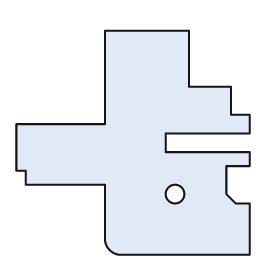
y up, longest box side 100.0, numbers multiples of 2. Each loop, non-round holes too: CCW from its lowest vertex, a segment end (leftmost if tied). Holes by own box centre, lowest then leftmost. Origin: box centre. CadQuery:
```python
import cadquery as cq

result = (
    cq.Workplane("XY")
    .moveTo(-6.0, -48.0)
    .lineTo(50.0, -48.0)
    .lineTo(50.0, -26.0)
    .lineTo(44.0, -26.0)
    .lineTo(40.0, -22.0)
    .lineTo(40.0, -10.0)
    .lineTo(50.0, -10.0)
    .lineTo(50.0, -4.0)
    .lineTo(14.0, -4.0)
    .lineTo(14.0, 4.0)
    .lineTo(50.0, 4.0)
    .lineTo(50.0, 12.0)
    .lineTo(42.0, 12.0)
    .lineTo(42.0, 24.0)
    .lineTo(24.0, 24.0)
    .lineTo(24.0, 48.0)
    .lineTo(-12.0, 48.0)
    .lineTo(-12.0, 8.0)
    .lineTo(-50.0, 8.0)
    .lineTo(-50.0, -12.0)
    .lineTo(-46.0, -12.0)
    .lineTo(-46.0, -18.0)
    .lineTo(-12.0, -18.0)
    .lineTo(-12.0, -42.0)
    .threePointArc((-10.0, -46.0), (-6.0, -48.0))
    .close()
    .moveTo(18.0, -22.0)
    .circle(4.0)
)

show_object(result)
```